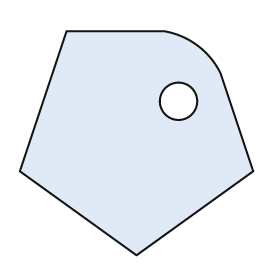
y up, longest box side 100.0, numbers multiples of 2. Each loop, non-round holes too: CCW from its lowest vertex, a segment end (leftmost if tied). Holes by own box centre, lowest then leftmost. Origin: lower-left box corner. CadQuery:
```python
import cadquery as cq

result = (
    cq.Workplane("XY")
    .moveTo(50.0, 0.0)
    .lineTo(100.0, 36.0)
    .lineTo(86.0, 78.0)
    .threePointArc((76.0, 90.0), (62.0, 96.0))
    .lineTo(20.0, 96.0)
    .lineTo(0.0, 36.0)
    .close()
    .moveTo(68.0, 66.0)
    .circle(8.0)
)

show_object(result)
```